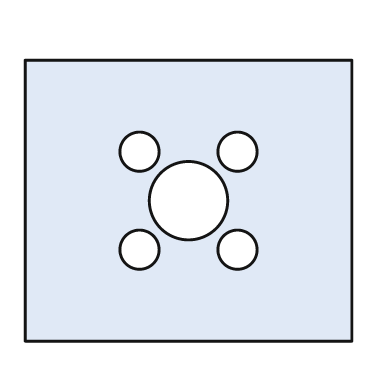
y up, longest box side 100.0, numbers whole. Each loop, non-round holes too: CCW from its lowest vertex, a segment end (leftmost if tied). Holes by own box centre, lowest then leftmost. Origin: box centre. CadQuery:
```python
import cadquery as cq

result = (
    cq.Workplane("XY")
    .moveTo(-50.0, -43.0)
    .lineTo(50.0, -43.0)
    .lineTo(50.0, 43.0)
    .lineTo(-50.0, 43.0)
    .close()
    .moveTo(-15.0, -15.0)
    .circle(6.0)
    .moveTo(15.0, -15.0)
    .circle(6.0)
    .moveTo(0.0, 0.0)
    .circle(12.0)
    .moveTo(-15.0, 15.0)
    .circle(6.0)
    .moveTo(15.0, 15.0)
    .circle(6.0)
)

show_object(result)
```